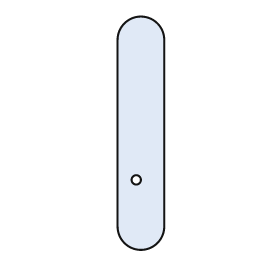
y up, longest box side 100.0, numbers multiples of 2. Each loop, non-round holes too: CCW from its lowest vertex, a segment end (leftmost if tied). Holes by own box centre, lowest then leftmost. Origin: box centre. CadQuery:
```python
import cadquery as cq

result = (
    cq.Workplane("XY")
    .moveTo(-10.0, -40.0)
    .threePointArc((0.0, -50.0), (10.0, -40.0))
    .lineTo(10.0, 40.0)
    .threePointArc((0.0, 50.0), (-10.0, 40.0))
    .close()
    .moveTo(-2.0, -20.0)
    .circle(2.0)
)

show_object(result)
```